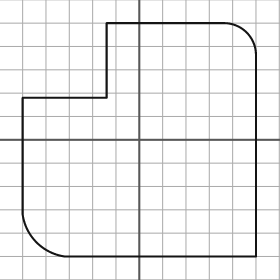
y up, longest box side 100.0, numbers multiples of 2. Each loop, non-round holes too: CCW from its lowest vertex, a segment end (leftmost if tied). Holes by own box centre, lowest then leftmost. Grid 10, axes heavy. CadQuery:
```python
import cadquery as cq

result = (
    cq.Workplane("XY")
    .moveTo(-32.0, -50.0)
    .lineTo(50.0, -50.0)
    .lineTo(50.0, 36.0)
    .threePointArc((46.0, 46.0), (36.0, 50.0))
    .lineTo(-14.0, 50.0)
    .lineTo(-14.0, 18.0)
    .lineTo(-50.0, 18.0)
    .lineTo(-50.0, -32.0)
    .threePointArc((-44.0, -44.0), (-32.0, -50.0))
    .close()
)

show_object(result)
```